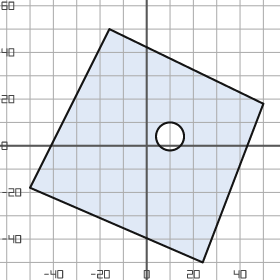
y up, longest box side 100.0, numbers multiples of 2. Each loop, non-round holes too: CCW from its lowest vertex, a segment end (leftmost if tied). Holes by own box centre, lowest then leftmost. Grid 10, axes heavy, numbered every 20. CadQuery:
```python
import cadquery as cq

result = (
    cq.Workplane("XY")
    .moveTo(24.0, -50.0)
    .lineTo(50.0, 18.0)
    .lineTo(-16.0, 50.0)
    .lineTo(-50.0, -18.0)
    .close()
    .moveTo(10.0, 4.0)
    .circle(6.0)
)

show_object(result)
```